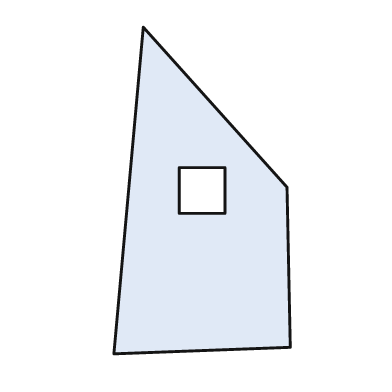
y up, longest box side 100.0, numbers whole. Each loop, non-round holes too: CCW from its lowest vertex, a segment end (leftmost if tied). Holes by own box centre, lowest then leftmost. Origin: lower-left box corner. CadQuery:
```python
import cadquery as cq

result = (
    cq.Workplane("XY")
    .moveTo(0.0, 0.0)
    .lineTo(54.0, 2.0)
    .lineTo(53.0, 51.0)
    .lineTo(9.0, 100.0)
    .close()
    .moveTo(20.0, 43.0)
    .lineTo(34.0, 43.0)
    .lineTo(34.0, 57.0)
    .lineTo(20.0, 57.0)
    .close()
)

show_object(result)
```